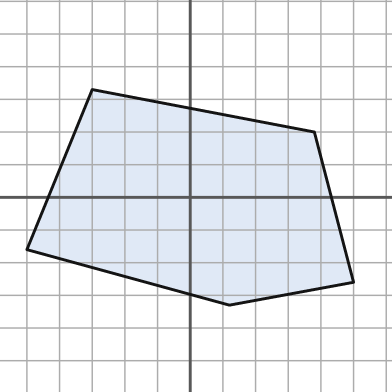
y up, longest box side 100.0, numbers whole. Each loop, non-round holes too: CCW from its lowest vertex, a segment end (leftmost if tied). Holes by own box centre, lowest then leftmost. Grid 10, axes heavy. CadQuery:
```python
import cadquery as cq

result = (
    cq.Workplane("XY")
    .moveTo(12.0, -33.0)
    .lineTo(50.0, -26.0)
    .lineTo(38.0, 20.0)
    .lineTo(-30.0, 33.0)
    .lineTo(-50.0, -16.0)
    .close()
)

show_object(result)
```